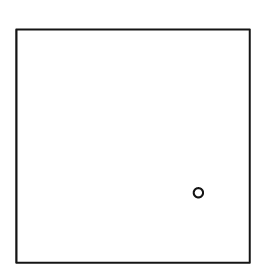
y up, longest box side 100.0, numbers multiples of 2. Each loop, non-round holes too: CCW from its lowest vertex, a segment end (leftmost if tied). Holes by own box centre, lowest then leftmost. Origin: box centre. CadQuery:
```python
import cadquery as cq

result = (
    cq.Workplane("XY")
    .moveTo(-50.0, -50.0)
    .lineTo(50.0, -50.0)
    .lineTo(50.0, 50.0)
    .lineTo(-50.0, 50.0)
    .close()
    .moveTo(28.0, -20.0)
    .circle(2.0)
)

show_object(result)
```